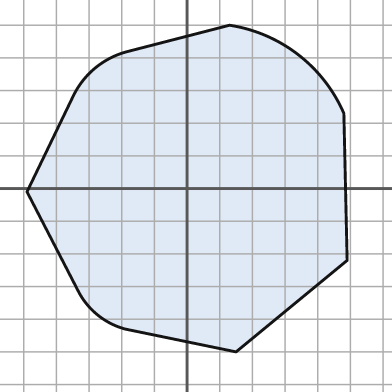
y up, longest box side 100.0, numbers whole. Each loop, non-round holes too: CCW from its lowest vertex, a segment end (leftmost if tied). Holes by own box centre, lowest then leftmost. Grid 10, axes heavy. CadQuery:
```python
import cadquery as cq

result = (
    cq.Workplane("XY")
    .moveTo(15.0, -50.0)
    .lineTo(49.0, -22.0)
    .lineTo(48.0, 23.0)
    .threePointArc((34.0, 41.0), (13.0, 50.0))
    .lineTo(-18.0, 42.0)
    .threePointArc((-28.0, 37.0), (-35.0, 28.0))
    .lineTo(-49.0, -1.0)
    .lineTo(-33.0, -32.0)
    .threePointArc((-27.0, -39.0), (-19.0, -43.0))
    .close()
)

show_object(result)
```